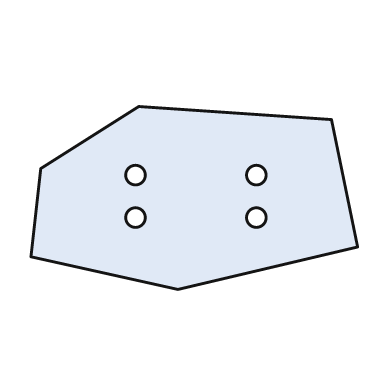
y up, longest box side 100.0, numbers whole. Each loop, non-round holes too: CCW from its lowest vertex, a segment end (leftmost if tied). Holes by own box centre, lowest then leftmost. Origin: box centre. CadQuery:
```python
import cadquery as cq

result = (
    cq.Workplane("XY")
    .moveTo(-5.0, -28.0)
    .lineTo(50.0, -15.0)
    .lineTo(42.0, 24.0)
    .lineTo(-17.0, 28.0)
    .lineTo(-47.0, 9.0)
    .lineTo(-50.0, -18.0)
    .close()
    .moveTo(-18.0, -6.0)
    .circle(3.0)
    .moveTo(19.0, -6.0)
    .circle(3.0)
    .moveTo(-18.0, 7.0)
    .circle(3.0)
    .moveTo(19.0, 7.0)
    .circle(3.0)
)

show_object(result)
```